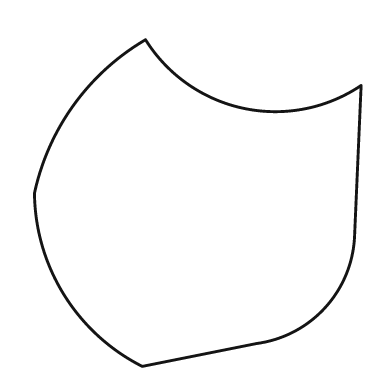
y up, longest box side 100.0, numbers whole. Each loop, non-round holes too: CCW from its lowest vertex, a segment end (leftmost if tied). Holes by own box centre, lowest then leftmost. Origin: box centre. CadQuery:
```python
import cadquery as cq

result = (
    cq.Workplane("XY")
    .moveTo(-17.0, -50.0)
    .lineTo(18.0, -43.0)
    .threePointArc((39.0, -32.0), (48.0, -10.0))
    .lineTo(50.0, 36.0)
    .threePointArc((14.0, 29.0), (-16.0, 50.0))
    .threePointArc((-38.0, 30.0), (-50.0, 3.0))
    .threePointArc((-41.0, -28.0), (-17.0, -50.0))
    .close()
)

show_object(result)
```